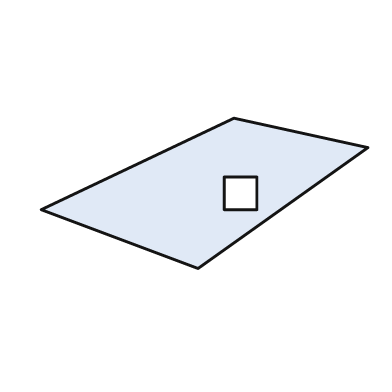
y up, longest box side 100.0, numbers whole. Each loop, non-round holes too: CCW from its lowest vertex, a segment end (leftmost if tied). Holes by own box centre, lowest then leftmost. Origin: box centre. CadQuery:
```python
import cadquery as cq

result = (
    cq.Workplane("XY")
    .moveTo(-2.0, -23.0)
    .lineTo(50.0, 14.0)
    .lineTo(9.0, 23.0)
    .lineTo(-50.0, -5.0)
    .close()
    .moveTo(6.0, -5.0)
    .lineTo(16.0, -5.0)
    .lineTo(16.0, 5.0)
    .lineTo(6.0, 5.0)
    .close()
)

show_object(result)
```